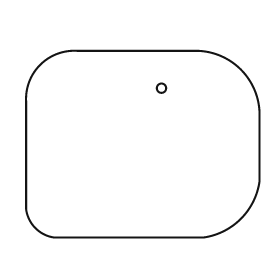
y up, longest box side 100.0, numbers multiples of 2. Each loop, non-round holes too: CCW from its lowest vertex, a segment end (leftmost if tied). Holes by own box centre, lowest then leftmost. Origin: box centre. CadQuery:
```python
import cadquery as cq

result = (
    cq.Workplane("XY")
    .moveTo(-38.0, -40.0)
    .lineTo(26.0, -40.0)
    .threePointArc((42.0, -32.0), (50.0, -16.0))
    .lineTo(50.0, 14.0)
    .threePointArc((42.0, 32.0), (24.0, 40.0))
    .lineTo(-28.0, 40.0)
    .threePointArc((-44.0, 34.0), (-50.0, 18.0))
    .lineTo(-50.0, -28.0)
    .threePointArc((-46.0, -36.0), (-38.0, -40.0))
    .close()
    .moveTo(8.0, 24.0)
    .circle(2.0)
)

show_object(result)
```